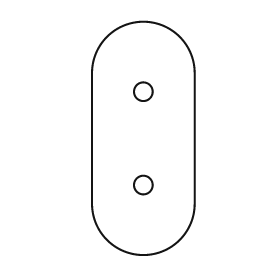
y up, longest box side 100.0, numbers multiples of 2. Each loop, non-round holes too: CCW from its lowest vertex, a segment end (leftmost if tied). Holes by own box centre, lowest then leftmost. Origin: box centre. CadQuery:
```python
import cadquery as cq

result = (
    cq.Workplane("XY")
    .moveTo(-22.0, -28.0)
    .threePointArc((0.0, -50.0), (22.0, -28.0))
    .lineTo(22.0, 28.0)
    .threePointArc((0.0, 50.0), (-22.0, 28.0))
    .close()
    .moveTo(0.0, -20.0)
    .circle(4.0)
    .moveTo(0.0, 20.0)
    .circle(4.0)
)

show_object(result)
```